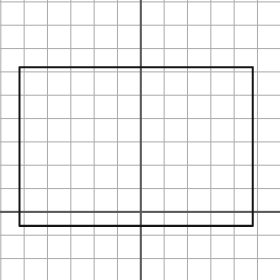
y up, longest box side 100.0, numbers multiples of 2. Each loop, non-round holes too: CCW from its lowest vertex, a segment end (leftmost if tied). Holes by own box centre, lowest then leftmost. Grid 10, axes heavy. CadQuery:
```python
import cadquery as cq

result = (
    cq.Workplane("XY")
    .moveTo(-52.0, -6.0)
    .lineTo(48.0, -6.0)
    .lineTo(48.0, 62.0)
    .lineTo(-52.0, 62.0)
    .close()
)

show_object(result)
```